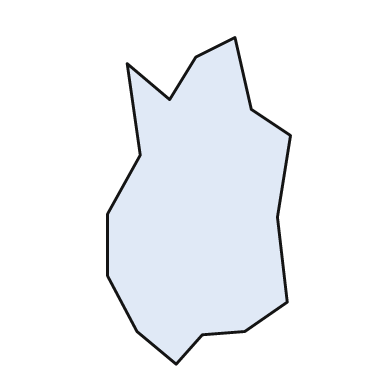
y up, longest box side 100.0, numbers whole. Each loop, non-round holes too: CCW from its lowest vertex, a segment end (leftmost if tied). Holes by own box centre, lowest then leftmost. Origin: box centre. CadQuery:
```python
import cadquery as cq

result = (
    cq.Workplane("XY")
    .moveTo(-7.0, -50.0)
    .lineTo(1.0, -41.0)
    .lineTo(14.0, -40.0)
    .lineTo(27.0, -31.0)
    .lineTo(24.0, -5.0)
    .lineTo(28.0, 20.0)
    .lineTo(16.0, 28.0)
    .lineTo(11.0, 50.0)
    .lineTo(-1.0, 44.0)
    .lineTo(-9.0, 31.0)
    .lineTo(-22.0, 42.0)
    .lineTo(-18.0, 14.0)
    .lineTo(-28.0, -4.0)
    .lineTo(-28.0, -23.0)
    .lineTo(-19.0, -40.0)
    .close()
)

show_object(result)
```